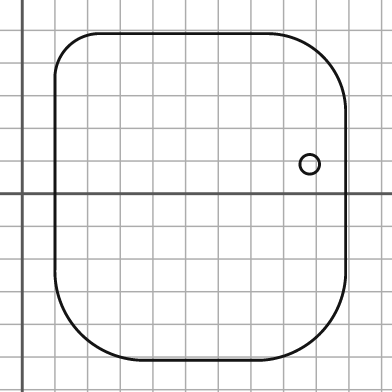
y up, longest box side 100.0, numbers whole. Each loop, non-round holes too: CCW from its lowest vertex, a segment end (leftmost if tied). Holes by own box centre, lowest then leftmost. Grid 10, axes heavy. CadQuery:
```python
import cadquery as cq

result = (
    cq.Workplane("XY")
    .moveTo(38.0, -51.0)
    .lineTo(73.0, -51.0)
    .threePointArc((91.0, -43.0), (99.0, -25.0))
    .lineTo(99.0, 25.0)
    .threePointArc((92.0, 42.0), (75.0, 49.0))
    .lineTo(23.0, 49.0)
    .threePointArc((14.0, 45.0), (10.0, 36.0))
    .lineTo(10.0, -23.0)
    .threePointArc((18.0, -43.0), (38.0, -51.0))
    .close()
    .moveTo(88.0, 9.0)
    .circle(3.0)
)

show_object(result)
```